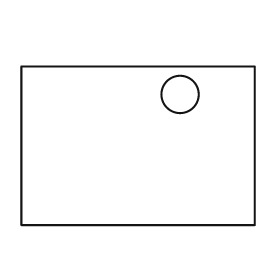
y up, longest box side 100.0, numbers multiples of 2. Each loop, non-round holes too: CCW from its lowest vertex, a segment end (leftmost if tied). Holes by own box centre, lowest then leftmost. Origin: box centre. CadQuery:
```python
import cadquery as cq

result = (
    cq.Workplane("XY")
    .moveTo(-50.0, -34.0)
    .lineTo(50.0, -34.0)
    .lineTo(50.0, 34.0)
    .lineTo(-50.0, 34.0)
    .close()
    .moveTo(18.0, 22.0)
    .circle(8.0)
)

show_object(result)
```